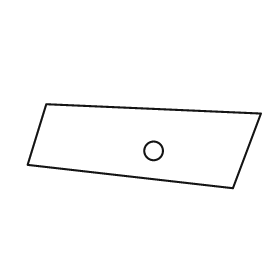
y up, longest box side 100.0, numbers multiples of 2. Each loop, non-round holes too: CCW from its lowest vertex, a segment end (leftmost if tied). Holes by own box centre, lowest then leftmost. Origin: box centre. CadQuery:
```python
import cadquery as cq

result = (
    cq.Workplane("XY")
    .moveTo(38.0, -18.0)
    .lineTo(50.0, 14.0)
    .lineTo(-42.0, 18.0)
    .lineTo(-50.0, -8.0)
    .close()
    .moveTo(4.0, -2.0)
    .circle(4.0)
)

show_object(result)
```